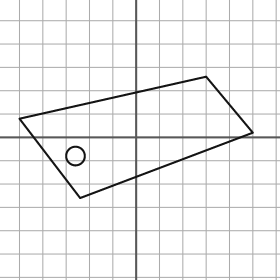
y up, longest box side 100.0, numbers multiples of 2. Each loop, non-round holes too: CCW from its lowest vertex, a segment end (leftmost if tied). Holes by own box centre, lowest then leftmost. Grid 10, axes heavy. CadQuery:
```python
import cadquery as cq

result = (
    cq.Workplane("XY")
    .moveTo(-24.0, -26.0)
    .lineTo(50.0, 2.0)
    .lineTo(30.0, 26.0)
    .lineTo(-50.0, 8.0)
    .close()
    .moveTo(-26.0, -8.0)
    .circle(4.0)
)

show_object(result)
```